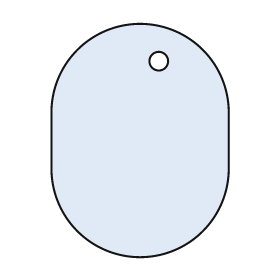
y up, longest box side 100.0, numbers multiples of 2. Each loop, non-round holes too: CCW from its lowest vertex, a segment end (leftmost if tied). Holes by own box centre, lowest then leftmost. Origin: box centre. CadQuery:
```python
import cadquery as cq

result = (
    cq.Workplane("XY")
    .moveTo(-38.0, -12.0)
    .threePointArc((0.0, -50.0), (38.0, -12.0))
    .lineTo(38.0, 12.0)
    .threePointArc((0.0, 50.0), (-38.0, 12.0))
    .close()
    .moveTo(8.0, 34.0)
    .circle(4.0)
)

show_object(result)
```